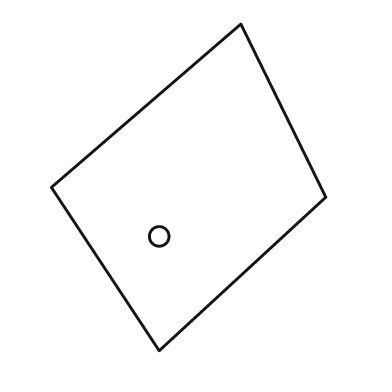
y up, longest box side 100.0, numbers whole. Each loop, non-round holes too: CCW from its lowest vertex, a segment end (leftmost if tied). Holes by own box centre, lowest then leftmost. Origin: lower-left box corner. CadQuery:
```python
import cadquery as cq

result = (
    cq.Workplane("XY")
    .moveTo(33.0, 0.0)
    .lineTo(84.0, 47.0)
    .lineTo(58.0, 100.0)
    .lineTo(0.0, 50.0)
    .close()
    .moveTo(33.0, 35.0)
    .circle(3.0)
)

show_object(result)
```